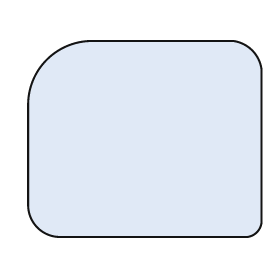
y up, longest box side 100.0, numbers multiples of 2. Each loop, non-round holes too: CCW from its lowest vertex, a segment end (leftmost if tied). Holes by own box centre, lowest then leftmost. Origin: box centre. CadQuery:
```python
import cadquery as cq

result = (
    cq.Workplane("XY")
    .moveTo(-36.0, -42.0)
    .lineTo(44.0, -42.0)
    .threePointArc((48.0, -40.0), (50.0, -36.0))
    .lineTo(50.0, 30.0)
    .threePointArc((46.0, 38.0), (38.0, 42.0))
    .lineTo(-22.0, 42.0)
    .threePointArc((-42.0, 34.0), (-50.0, 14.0))
    .lineTo(-50.0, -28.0)
    .threePointArc((-46.0, -38.0), (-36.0, -42.0))
    .close()
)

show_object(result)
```